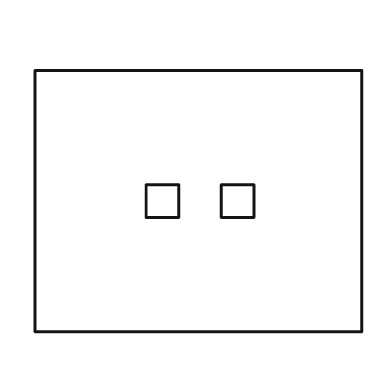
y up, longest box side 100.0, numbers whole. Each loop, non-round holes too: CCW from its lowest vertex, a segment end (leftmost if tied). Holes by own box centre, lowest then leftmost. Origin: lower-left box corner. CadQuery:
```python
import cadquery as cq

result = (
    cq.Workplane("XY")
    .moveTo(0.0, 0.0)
    .lineTo(100.0, 0.0)
    .lineTo(100.0, 80.0)
    .lineTo(0.0, 80.0)
    .close()
    .moveTo(34.0, 35.0)
    .lineTo(44.0, 35.0)
    .lineTo(44.0, 45.0)
    .lineTo(34.0, 45.0)
    .close()
    .moveTo(57.0, 35.0)
    .lineTo(67.0, 35.0)
    .lineTo(67.0, 45.0)
    .lineTo(57.0, 45.0)
    .close()
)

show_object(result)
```